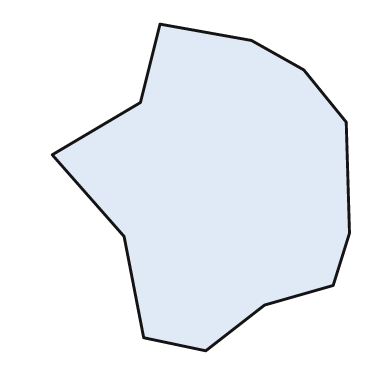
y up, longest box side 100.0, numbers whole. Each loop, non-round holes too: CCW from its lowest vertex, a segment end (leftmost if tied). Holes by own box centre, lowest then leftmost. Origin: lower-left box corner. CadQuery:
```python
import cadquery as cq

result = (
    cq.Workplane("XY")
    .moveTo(47.0, 0.0)
    .lineTo(65.0, 14.0)
    .lineTo(86.0, 20.0)
    .lineTo(91.0, 36.0)
    .lineTo(90.0, 70.0)
    .lineTo(77.0, 86.0)
    .lineTo(61.0, 95.0)
    .lineTo(33.0, 100.0)
    .lineTo(27.0, 76.0)
    .lineTo(0.0, 60.0)
    .lineTo(22.0, 35.0)
    .lineTo(28.0, 4.0)
    .close()
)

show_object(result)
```